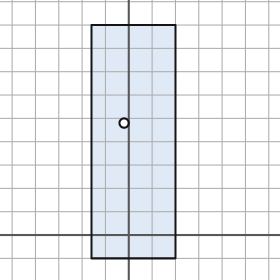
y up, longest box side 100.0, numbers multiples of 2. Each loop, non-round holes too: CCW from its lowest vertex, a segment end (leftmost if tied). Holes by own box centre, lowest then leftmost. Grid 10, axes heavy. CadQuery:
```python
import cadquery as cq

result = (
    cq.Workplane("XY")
    .moveTo(-16.0, -10.0)
    .lineTo(20.0, -10.0)
    .lineTo(20.0, 90.0)
    .lineTo(-16.0, 90.0)
    .close()
    .moveTo(-2.0, 48.0)
    .circle(2.0)
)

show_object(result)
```